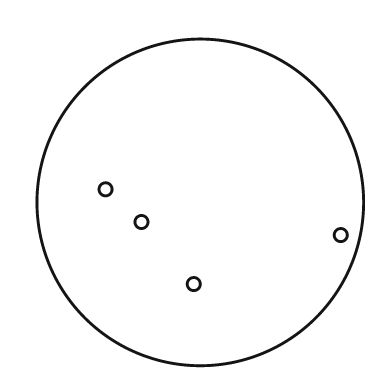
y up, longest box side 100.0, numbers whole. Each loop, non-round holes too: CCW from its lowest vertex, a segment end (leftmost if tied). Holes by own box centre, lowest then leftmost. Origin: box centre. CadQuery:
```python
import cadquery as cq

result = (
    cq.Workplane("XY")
    .moveTo(0.0, 0.0)
    .circle(50.0)
    .moveTo(-2.0, -25.0)
    .circle(2.0)
    .moveTo(43.0, -10.0)
    .circle(2.0)
    .moveTo(-18.0, -6.0)
    .circle(2.0)
    .moveTo(-29.0, 4.0)
    .circle(2.0)
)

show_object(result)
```